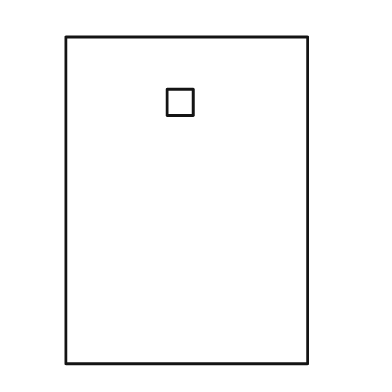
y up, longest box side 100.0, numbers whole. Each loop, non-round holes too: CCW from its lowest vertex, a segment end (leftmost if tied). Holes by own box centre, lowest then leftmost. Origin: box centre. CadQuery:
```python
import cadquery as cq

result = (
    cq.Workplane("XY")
    .moveTo(-37.0, -50.0)
    .lineTo(37.0, -50.0)
    .lineTo(37.0, 50.0)
    .lineTo(-37.0, 50.0)
    .close()
    .moveTo(-6.0, 26.0)
    .lineTo(2.0, 26.0)
    .lineTo(2.0, 34.0)
    .lineTo(-6.0, 34.0)
    .close()
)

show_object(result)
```